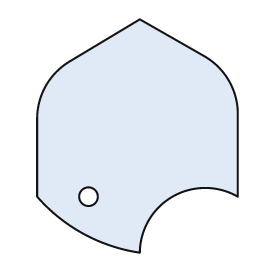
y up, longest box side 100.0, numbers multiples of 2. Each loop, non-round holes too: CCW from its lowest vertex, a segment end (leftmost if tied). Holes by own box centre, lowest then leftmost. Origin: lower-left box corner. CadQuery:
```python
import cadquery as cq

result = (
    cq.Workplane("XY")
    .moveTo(44.0, 0.0)
    .threePointArc((58.0, 24.0), (86.0, 24.0))
    .lineTo(86.0, 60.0)
    .threePointArc((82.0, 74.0), (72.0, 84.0))
    .lineTo(44.0, 100.0)
    .lineTo(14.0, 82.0)
    .threePointArc((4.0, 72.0), (0.0, 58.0))
    .lineTo(0.0, 24.0)
    .threePointArc((20.0, 8.0), (44.0, 0.0))
    .close()
    .moveTo(22.0, 24.0)
    .circle(4.0)
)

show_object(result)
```